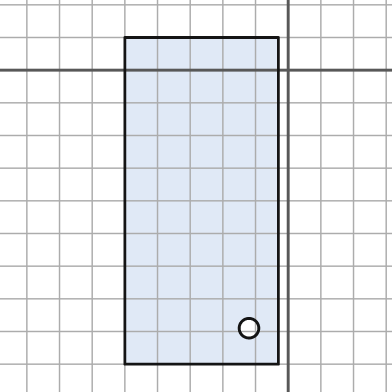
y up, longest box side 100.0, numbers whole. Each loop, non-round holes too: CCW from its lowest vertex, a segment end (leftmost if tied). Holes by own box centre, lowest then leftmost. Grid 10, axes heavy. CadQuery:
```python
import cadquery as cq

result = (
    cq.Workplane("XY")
    .moveTo(-50.0, -90.0)
    .lineTo(-3.0, -90.0)
    .lineTo(-3.0, 10.0)
    .lineTo(-50.0, 10.0)
    .close()
    .moveTo(-12.0, -79.0)
    .circle(3.0)
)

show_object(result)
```